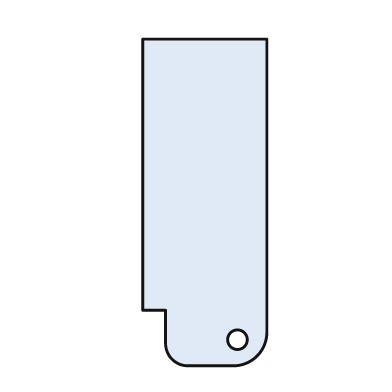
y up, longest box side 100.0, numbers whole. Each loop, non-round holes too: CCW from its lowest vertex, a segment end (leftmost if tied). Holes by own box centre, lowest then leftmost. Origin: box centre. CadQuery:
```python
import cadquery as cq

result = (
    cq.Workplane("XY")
    .moveTo(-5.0, -50.0)
    .lineTo(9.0, -50.0)
    .threePointArc((16.0, -47.0), (19.0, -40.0))
    .lineTo(19.0, 50.0)
    .lineTo(-19.0, 50.0)
    .lineTo(-19.0, -33.0)
    .lineTo(-12.0, -33.0)
    .lineTo(-12.0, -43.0)
    .threePointArc((-10.0, -48.0), (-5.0, -50.0))
    .close()
    .moveTo(10.0, -42.0)
    .circle(3.0)
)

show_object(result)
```